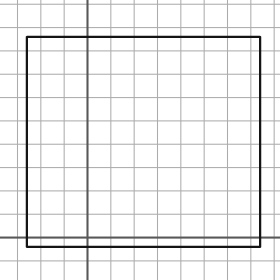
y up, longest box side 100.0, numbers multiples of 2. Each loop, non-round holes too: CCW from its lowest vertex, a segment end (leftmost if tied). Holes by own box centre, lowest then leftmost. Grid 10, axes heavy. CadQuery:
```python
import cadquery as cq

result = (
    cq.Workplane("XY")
    .moveTo(-26.0, -4.0)
    .lineTo(74.0, -4.0)
    .lineTo(74.0, 86.0)
    .lineTo(-26.0, 86.0)
    .close()
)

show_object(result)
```